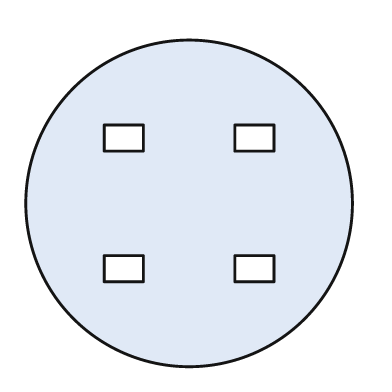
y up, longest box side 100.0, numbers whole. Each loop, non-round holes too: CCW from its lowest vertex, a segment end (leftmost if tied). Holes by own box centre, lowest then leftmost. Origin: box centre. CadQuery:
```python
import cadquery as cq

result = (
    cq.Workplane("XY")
    .moveTo(0.0, 0.0)
    .circle(50.0)
    .moveTo(-26.0, -24.0)
    .lineTo(-14.0, -24.0)
    .lineTo(-14.0, -16.0)
    .lineTo(-26.0, -16.0)
    .close()
    .moveTo(14.0, -24.0)
    .lineTo(26.0, -24.0)
    .lineTo(26.0, -16.0)
    .lineTo(14.0, -16.0)
    .close()
    .moveTo(-26.0, 16.0)
    .lineTo(-14.0, 16.0)
    .lineTo(-14.0, 24.0)
    .lineTo(-26.0, 24.0)
    .close()
    .moveTo(14.0, 16.0)
    .lineTo(26.0, 16.0)
    .lineTo(26.0, 24.0)
    .lineTo(14.0, 24.0)
    .close()
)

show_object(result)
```